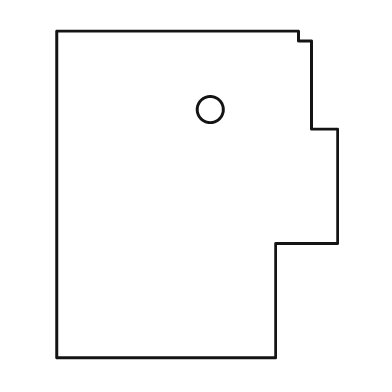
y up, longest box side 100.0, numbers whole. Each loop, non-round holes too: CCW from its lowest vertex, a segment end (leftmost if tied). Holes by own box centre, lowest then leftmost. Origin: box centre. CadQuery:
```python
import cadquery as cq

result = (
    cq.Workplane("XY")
    .moveTo(-43.0, -50.0)
    .lineTo(24.0, -50.0)
    .lineTo(24.0, -15.0)
    .lineTo(43.0, -15.0)
    .lineTo(43.0, 20.0)
    .lineTo(35.0, 20.0)
    .lineTo(35.0, 47.0)
    .lineTo(31.0, 47.0)
    .lineTo(31.0, 50.0)
    .lineTo(-43.0, 50.0)
    .close()
    .moveTo(4.0, 26.0)
    .circle(4.0)
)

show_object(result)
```